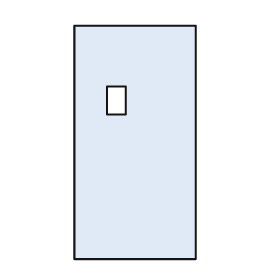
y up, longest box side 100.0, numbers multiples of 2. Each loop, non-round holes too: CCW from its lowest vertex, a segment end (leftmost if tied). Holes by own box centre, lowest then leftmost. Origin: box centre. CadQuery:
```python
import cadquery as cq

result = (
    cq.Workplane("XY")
    .moveTo(-26.0, -50.0)
    .lineTo(26.0, -50.0)
    .lineTo(26.0, 50.0)
    .lineTo(-26.0, 50.0)
    .close()
    .moveTo(-12.0, 12.0)
    .lineTo(-4.0, 12.0)
    .lineTo(-4.0, 24.0)
    .lineTo(-12.0, 24.0)
    .close()
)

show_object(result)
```